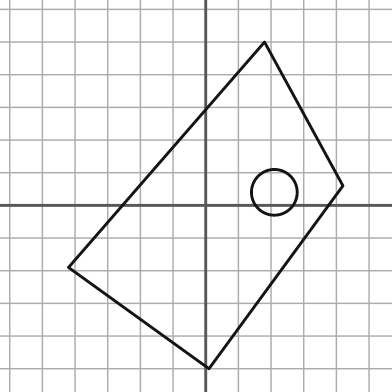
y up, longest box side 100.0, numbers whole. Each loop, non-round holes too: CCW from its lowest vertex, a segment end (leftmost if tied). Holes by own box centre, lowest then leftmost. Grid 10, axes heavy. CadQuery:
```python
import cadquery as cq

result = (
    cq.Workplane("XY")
    .moveTo(1.0, -50.0)
    .lineTo(42.0, 6.0)
    .lineTo(18.0, 50.0)
    .lineTo(-42.0, -19.0)
    .close()
    .moveTo(21.0, 4.0)
    .circle(7.0)
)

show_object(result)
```